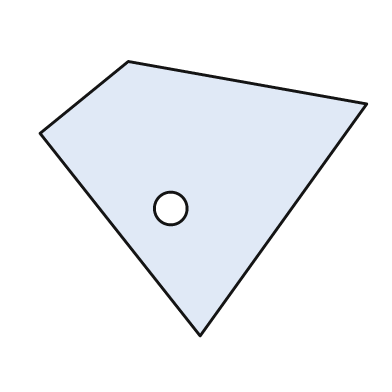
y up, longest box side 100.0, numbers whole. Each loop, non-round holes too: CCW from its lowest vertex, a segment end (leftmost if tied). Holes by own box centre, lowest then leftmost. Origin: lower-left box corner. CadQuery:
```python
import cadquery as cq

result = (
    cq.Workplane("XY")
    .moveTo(49.0, 0.0)
    .lineTo(100.0, 71.0)
    .lineTo(27.0, 84.0)
    .lineTo(0.0, 62.0)
    .close()
    .moveTo(40.0, 39.0)
    .circle(5.0)
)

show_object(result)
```